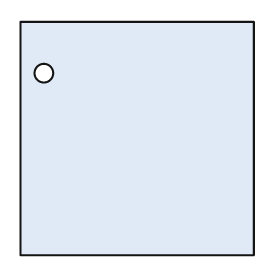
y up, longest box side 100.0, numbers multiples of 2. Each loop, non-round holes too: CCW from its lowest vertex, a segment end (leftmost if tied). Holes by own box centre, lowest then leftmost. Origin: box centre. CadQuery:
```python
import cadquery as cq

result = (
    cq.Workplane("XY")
    .moveTo(-50.0, -50.0)
    .lineTo(50.0, -50.0)
    .lineTo(50.0, 50.0)
    .lineTo(-50.0, 50.0)
    .close()
    .moveTo(-40.0, 28.0)
    .circle(4.0)
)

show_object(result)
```